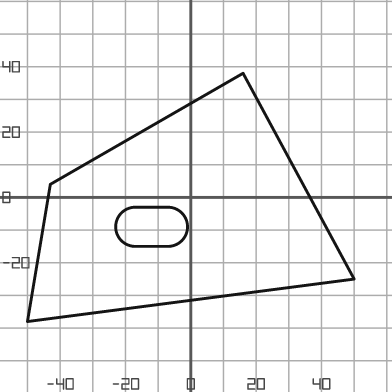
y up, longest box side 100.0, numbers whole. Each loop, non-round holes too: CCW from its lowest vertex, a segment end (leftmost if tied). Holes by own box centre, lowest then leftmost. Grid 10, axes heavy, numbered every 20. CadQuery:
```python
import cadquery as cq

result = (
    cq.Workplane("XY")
    .moveTo(-50.0, -38.0)
    .lineTo(50.0, -25.0)
    .lineTo(16.0, 38.0)
    .lineTo(-43.0, 4.0)
    .close()
    .moveTo(-17.0, -15.0)
    .lineTo(-7.0, -15.0)
    .threePointArc((-1.0, -9.0), (-7.0, -3.0))
    .lineTo(-17.0, -3.0)
    .threePointArc((-23.0, -9.0), (-17.0, -15.0))
    .close()
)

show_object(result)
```